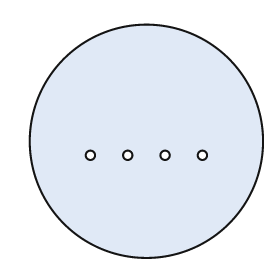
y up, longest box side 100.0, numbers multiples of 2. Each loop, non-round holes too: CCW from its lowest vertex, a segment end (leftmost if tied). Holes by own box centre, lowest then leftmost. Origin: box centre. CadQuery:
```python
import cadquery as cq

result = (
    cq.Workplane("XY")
    .moveTo(0.0, 0.0)
    .circle(50.0)
    .moveTo(-24.0, -6.0)
    .circle(2.0)
    .moveTo(-8.0, -6.0)
    .circle(2.0)
    .moveTo(8.0, -6.0)
    .circle(2.0)
    .moveTo(24.0, -6.0)
    .circle(2.0)
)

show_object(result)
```